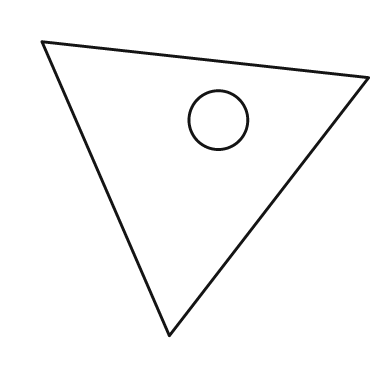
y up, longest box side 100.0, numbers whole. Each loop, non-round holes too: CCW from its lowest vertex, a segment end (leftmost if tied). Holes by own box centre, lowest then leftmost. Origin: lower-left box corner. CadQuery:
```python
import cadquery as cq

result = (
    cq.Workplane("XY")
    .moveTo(39.0, 0.0)
    .lineTo(100.0, 79.0)
    .lineTo(0.0, 90.0)
    .close()
    .moveTo(54.0, 66.0)
    .circle(9.0)
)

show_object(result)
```